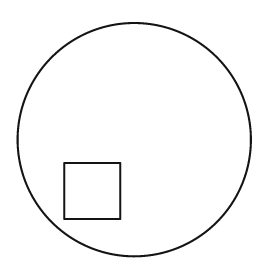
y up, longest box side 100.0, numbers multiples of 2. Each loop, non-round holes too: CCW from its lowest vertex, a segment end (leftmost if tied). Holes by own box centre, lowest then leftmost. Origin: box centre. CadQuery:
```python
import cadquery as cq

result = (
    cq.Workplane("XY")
    .moveTo(0.0, 0.0)
    .circle(50.0)
    .moveTo(-30.0, -34.0)
    .lineTo(-6.0, -34.0)
    .lineTo(-6.0, -10.0)
    .lineTo(-30.0, -10.0)
    .close()
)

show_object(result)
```